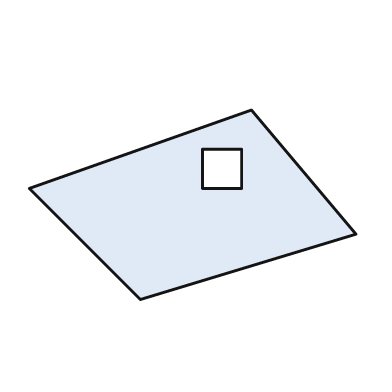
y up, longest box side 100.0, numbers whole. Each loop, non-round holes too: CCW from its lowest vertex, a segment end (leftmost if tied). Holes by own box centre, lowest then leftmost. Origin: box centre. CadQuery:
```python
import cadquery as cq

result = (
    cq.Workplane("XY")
    .moveTo(-16.0, -29.0)
    .lineTo(50.0, -9.0)
    .lineTo(18.0, 29.0)
    .lineTo(-50.0, 5.0)
    .close()
    .moveTo(3.0, 5.0)
    .lineTo(15.0, 5.0)
    .lineTo(15.0, 17.0)
    .lineTo(3.0, 17.0)
    .close()
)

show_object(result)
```